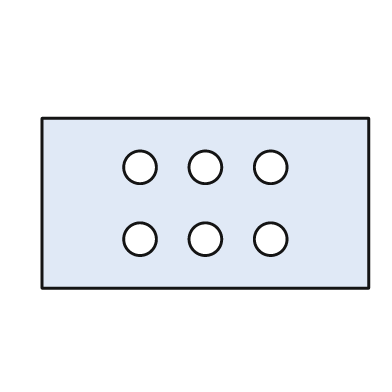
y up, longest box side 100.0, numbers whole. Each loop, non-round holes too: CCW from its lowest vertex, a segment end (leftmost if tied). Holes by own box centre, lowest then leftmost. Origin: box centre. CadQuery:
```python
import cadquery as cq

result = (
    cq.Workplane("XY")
    .moveTo(-50.0, -26.0)
    .lineTo(50.0, -26.0)
    .lineTo(50.0, 26.0)
    .lineTo(-50.0, 26.0)
    .close()
    .moveTo(-20.0, -11.0)
    .circle(5.0)
    .moveTo(0.0, -11.0)
    .circle(5.0)
    .moveTo(20.0, -11.0)
    .circle(5.0)
    .moveTo(-20.0, 11.0)
    .circle(5.0)
    .moveTo(0.0, 11.0)
    .circle(5.0)
    .moveTo(20.0, 11.0)
    .circle(5.0)
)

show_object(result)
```